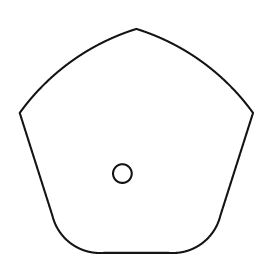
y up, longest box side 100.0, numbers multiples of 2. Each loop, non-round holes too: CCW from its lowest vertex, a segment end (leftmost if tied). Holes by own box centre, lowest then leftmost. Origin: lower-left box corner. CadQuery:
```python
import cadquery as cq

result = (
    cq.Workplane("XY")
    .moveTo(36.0, 0.0)
    .lineTo(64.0, 0.0)
    .threePointArc((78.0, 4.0), (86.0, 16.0))
    .lineTo(100.0, 60.0)
    .threePointArc((78.0, 82.0), (50.0, 96.0))
    .threePointArc((22.0, 82.0), (0.0, 60.0))
    .lineTo(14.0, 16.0)
    .threePointArc((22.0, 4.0), (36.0, 0.0))
    .close()
    .moveTo(44.0, 34.0)
    .circle(4.0)
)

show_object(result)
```